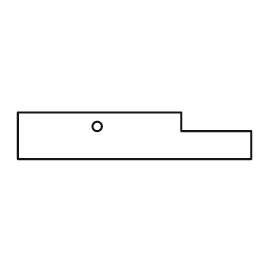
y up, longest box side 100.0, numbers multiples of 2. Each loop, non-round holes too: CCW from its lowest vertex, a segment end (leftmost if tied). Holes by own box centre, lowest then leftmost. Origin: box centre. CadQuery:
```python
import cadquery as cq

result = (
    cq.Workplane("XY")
    .moveTo(-50.0, -10.0)
    .lineTo(50.0, -10.0)
    .lineTo(50.0, 2.0)
    .lineTo(20.0, 2.0)
    .lineTo(20.0, 10.0)
    .lineTo(-50.0, 10.0)
    .close()
    .moveTo(-16.0, 4.0)
    .circle(2.0)
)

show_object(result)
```